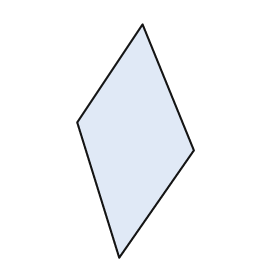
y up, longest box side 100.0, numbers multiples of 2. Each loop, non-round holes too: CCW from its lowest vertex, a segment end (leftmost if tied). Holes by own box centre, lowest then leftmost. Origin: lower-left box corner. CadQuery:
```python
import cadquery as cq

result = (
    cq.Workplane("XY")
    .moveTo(18.0, 0.0)
    .lineTo(50.0, 46.0)
    .lineTo(28.0, 100.0)
    .lineTo(0.0, 58.0)
    .close()
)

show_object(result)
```